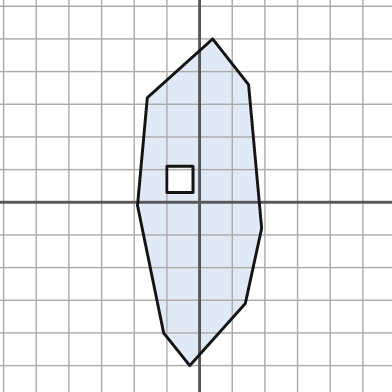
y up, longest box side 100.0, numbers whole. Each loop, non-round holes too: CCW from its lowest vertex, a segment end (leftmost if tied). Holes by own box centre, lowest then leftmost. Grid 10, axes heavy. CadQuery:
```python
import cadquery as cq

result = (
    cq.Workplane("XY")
    .moveTo(-3.0, -50.0)
    .lineTo(14.0, -31.0)
    .lineTo(19.0, -8.0)
    .lineTo(15.0, 36.0)
    .lineTo(4.0, 50.0)
    .lineTo(-16.0, 32.0)
    .lineTo(-19.0, -1.0)
    .lineTo(-11.0, -40.0)
    .close()
    .moveTo(-10.0, 3.0)
    .lineTo(-2.0, 3.0)
    .lineTo(-2.0, 11.0)
    .lineTo(-10.0, 11.0)
    .close()
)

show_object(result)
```